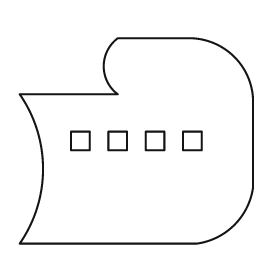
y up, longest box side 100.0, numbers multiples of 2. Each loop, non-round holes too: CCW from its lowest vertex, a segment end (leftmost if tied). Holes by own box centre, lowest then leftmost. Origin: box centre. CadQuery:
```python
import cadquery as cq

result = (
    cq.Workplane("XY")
    .moveTo(-50.0, -44.0)
    .lineTo(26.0, -44.0)
    .threePointArc((42.0, -36.0), (50.0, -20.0))
    .lineTo(50.0, 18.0)
    .threePointArc((42.0, 36.0), (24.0, 44.0))
    .lineTo(-8.0, 44.0)
    .threePointArc((-14.0, 32.0), (-8.0, 20.0))
    .lineTo(-50.0, 20.0)
    .threePointArc((-40.0, -12.0), (-50.0, -44.0))
    .close()
    .moveTo(-28.0, -4.0)
    .lineTo(-20.0, -4.0)
    .lineTo(-20.0, 4.0)
    .lineTo(-28.0, 4.0)
    .close()
    .moveTo(-12.0, -4.0)
    .lineTo(-4.0, -4.0)
    .lineTo(-4.0, 4.0)
    .lineTo(-12.0, 4.0)
    .close()
    .moveTo(4.0, -4.0)
    .lineTo(12.0, -4.0)
    .lineTo(12.0, 4.0)
    .lineTo(4.0, 4.0)
    .close()
    .moveTo(20.0, -4.0)
    .lineTo(28.0, -4.0)
    .lineTo(28.0, 4.0)
    .lineTo(20.0, 4.0)
    .close()
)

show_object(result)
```